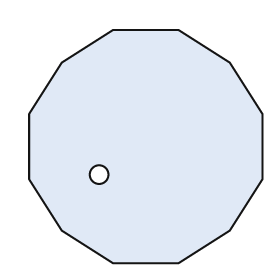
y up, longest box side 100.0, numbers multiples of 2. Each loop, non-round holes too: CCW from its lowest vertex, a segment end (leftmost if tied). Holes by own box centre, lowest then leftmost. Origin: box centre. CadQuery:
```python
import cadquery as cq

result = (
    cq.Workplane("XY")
    .moveTo(-14.0, -50.0)
    .lineTo(14.0, -50.0)
    .lineTo(36.0, -36.0)
    .lineTo(50.0, -14.0)
    .lineTo(50.0, 14.0)
    .lineTo(36.0, 36.0)
    .lineTo(14.0, 50.0)
    .lineTo(-14.0, 50.0)
    .lineTo(-36.0, 36.0)
    .lineTo(-50.0, 14.0)
    .lineTo(-50.0, -14.0)
    .lineTo(-36.0, -36.0)
    .close()
    .moveTo(-20.0, -12.0)
    .circle(4.0)
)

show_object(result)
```